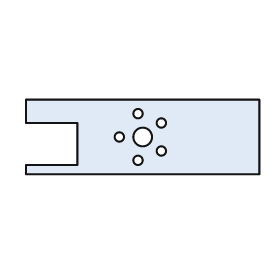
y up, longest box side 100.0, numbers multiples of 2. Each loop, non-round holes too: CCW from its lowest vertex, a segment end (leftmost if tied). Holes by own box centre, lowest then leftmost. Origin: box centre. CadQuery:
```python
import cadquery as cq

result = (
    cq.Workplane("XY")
    .moveTo(-50.0, -16.0)
    .lineTo(50.0, -16.0)
    .lineTo(50.0, 16.0)
    .lineTo(-50.0, 16.0)
    .lineTo(-50.0, 6.0)
    .lineTo(-28.0, 6.0)
    .lineTo(-28.0, -12.0)
    .lineTo(-50.0, -12.0)
    .close()
    .moveTo(-2.0, -10.0)
    .circle(2.0)
    .moveTo(8.0, -6.0)
    .circle(2.0)
    .moveTo(-10.0, 0.0)
    .circle(2.0)
    .moveTo(0.0, 0.0)
    .circle(4.0)
    .moveTo(8.0, 6.0)
    .circle(2.0)
    .moveTo(-2.0, 10.0)
    .circle(2.0)
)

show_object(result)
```